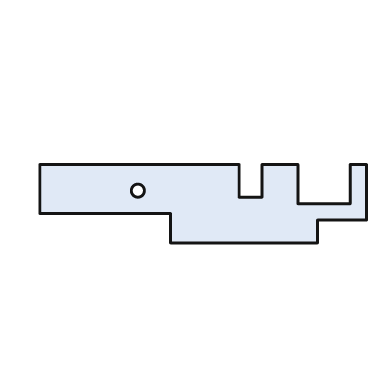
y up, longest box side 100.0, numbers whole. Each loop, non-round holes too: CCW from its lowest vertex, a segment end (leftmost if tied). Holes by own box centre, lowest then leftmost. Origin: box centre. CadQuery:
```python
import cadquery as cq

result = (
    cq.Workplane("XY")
    .moveTo(-10.0, -12.0)
    .lineTo(35.0, -12.0)
    .lineTo(35.0, -5.0)
    .lineTo(50.0, -5.0)
    .lineTo(50.0, 12.0)
    .lineTo(45.0, 12.0)
    .lineTo(45.0, 0.0)
    .lineTo(29.0, 0.0)
    .lineTo(29.0, 12.0)
    .lineTo(18.0, 12.0)
    .lineTo(18.0, 2.0)
    .lineTo(11.0, 2.0)
    .lineTo(11.0, 12.0)
    .lineTo(-50.0, 12.0)
    .lineTo(-50.0, -3.0)
    .lineTo(-10.0, -3.0)
    .close()
    .moveTo(-20.0, 4.0)
    .circle(2.0)
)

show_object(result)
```